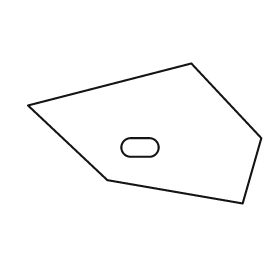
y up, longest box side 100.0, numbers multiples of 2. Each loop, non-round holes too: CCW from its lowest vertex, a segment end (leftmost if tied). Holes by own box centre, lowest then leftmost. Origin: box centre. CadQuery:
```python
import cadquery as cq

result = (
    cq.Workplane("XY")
    .moveTo(42.0, -30.0)
    .lineTo(50.0, -2.0)
    .lineTo(20.0, 30.0)
    .lineTo(-50.0, 12.0)
    .lineTo(-16.0, -20.0)
    .close()
    .moveTo(-6.0, -10.0)
    .lineTo(2.0, -10.0)
    .threePointArc((6.0, -6.0), (2.0, -2.0))
    .lineTo(-6.0, -2.0)
    .threePointArc((-10.0, -6.0), (-6.0, -10.0))
    .close()
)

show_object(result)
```